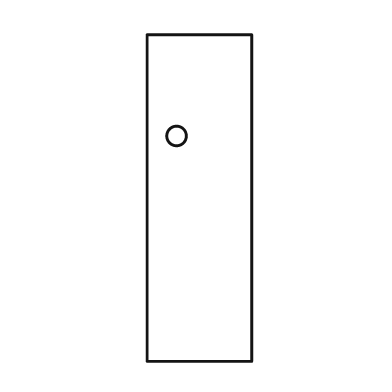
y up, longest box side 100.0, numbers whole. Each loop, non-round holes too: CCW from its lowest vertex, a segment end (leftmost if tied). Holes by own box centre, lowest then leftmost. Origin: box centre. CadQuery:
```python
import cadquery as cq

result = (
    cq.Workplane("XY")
    .moveTo(-16.0, -50.0)
    .lineTo(16.0, -50.0)
    .lineTo(16.0, 50.0)
    .lineTo(-16.0, 50.0)
    .close()
    .moveTo(-7.0, 19.0)
    .circle(3.0)
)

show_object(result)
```